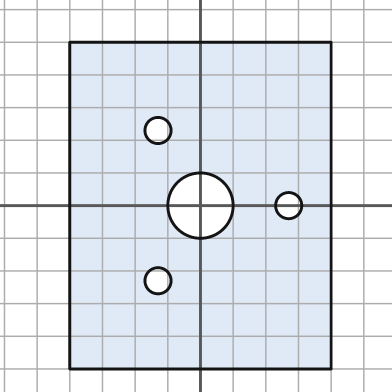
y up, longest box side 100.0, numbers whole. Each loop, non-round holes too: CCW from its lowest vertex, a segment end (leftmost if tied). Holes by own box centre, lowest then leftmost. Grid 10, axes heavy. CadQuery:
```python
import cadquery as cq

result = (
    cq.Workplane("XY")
    .moveTo(-40.0, -50.0)
    .lineTo(40.0, -50.0)
    .lineTo(40.0, 50.0)
    .lineTo(-40.0, 50.0)
    .close()
    .moveTo(-13.0, -23.0)
    .circle(4.0)
    .moveTo(0.0, 0.0)
    .circle(10.0)
    .moveTo(27.0, 0.0)
    .circle(4.0)
    .moveTo(-13.0, 23.0)
    .circle(4.0)
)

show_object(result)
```